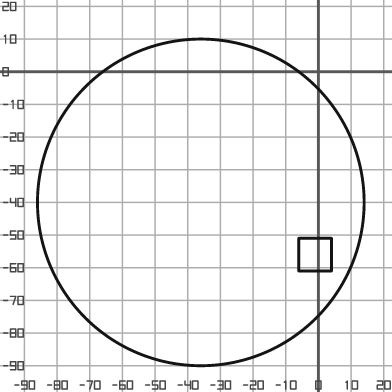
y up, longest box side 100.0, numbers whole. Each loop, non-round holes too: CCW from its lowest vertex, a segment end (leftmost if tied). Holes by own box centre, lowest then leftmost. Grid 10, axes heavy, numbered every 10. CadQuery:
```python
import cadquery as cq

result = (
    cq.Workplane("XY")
    .moveTo(-36.0, -40.0)
    .circle(50.0)
    .moveTo(-6.0, -61.0)
    .lineTo(4.0, -61.0)
    .lineTo(4.0, -51.0)
    .lineTo(-6.0, -51.0)
    .close()
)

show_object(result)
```